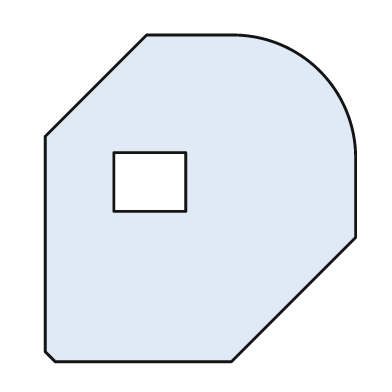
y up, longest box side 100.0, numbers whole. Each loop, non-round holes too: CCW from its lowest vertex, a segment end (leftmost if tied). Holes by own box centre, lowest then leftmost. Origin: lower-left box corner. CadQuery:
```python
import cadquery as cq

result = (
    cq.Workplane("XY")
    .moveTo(3.0, 0.0)
    .lineTo(57.0, 0.0)
    .lineTo(95.0, 38.0)
    .lineTo(95.0, 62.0)
    .threePointArc((84.0, 89.0), (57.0, 100.0))
    .lineTo(31.0, 100.0)
    .lineTo(0.0, 69.0)
    .lineTo(0.0, 3.0)
    .close()
    .moveTo(21.0, 46.0)
    .lineTo(43.0, 46.0)
    .lineTo(43.0, 64.0)
    .lineTo(21.0, 64.0)
    .close()
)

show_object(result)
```